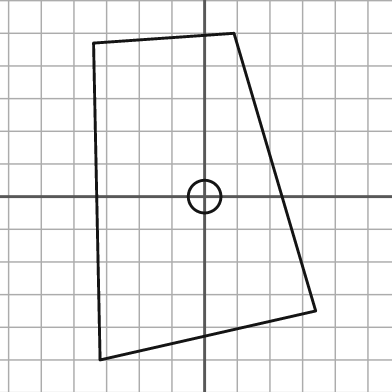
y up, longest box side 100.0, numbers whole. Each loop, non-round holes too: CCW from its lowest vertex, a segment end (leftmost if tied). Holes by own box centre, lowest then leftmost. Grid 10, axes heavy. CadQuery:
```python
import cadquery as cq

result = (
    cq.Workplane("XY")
    .moveTo(-32.0, -50.0)
    .lineTo(34.0, -35.0)
    .lineTo(9.0, 50.0)
    .lineTo(-34.0, 47.0)
    .close()
    .moveTo(0.0, 0.0)
    .circle(5.0)
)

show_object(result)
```